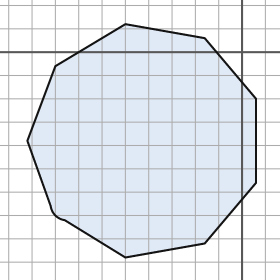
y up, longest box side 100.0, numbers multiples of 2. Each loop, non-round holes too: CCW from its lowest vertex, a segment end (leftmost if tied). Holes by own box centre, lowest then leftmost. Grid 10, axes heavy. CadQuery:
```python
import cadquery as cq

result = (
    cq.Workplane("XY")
    .moveTo(-50.0, -88.0)
    .lineTo(-16.0, -82.0)
    .lineTo(6.0, -56.0)
    .lineTo(6.0, -20.0)
    .lineTo(-16.0, 6.0)
    .lineTo(-50.0, 12.0)
    .lineTo(-80.0, -6.0)
    .lineTo(-92.0, -38.0)
    .lineTo(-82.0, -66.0)
    .threePointArc((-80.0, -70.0), (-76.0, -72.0))
    .close()
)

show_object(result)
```